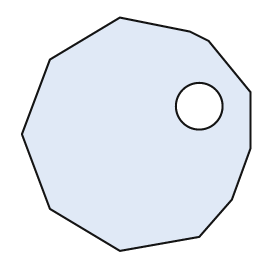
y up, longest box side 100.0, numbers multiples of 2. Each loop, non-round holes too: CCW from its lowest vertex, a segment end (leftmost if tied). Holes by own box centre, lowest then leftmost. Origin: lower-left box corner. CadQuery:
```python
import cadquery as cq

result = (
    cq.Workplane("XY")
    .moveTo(42.0, 0.0)
    .lineTo(76.0, 6.0)
    .lineTo(90.0, 22.0)
    .lineTo(98.0, 44.0)
    .lineTo(98.0, 68.0)
    .lineTo(80.0, 90.0)
    .lineTo(72.0, 94.0)
    .lineTo(42.0, 100.0)
    .lineTo(12.0, 82.0)
    .lineTo(0.0, 50.0)
    .lineTo(12.0, 18.0)
    .close()
    .moveTo(76.0, 62.0)
    .circle(10.0)
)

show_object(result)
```